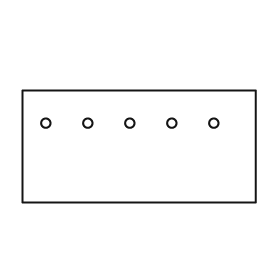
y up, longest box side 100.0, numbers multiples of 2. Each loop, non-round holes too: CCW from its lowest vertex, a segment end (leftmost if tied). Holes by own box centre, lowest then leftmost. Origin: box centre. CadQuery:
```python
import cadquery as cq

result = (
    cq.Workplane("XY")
    .moveTo(-50.0, -24.0)
    .lineTo(50.0, -24.0)
    .lineTo(50.0, 24.0)
    .lineTo(-50.0, 24.0)
    .close()
    .moveTo(-40.0, 10.0)
    .circle(2.0)
    .moveTo(-22.0, 10.0)
    .circle(2.0)
    .moveTo(-4.0, 10.0)
    .circle(2.0)
    .moveTo(14.0, 10.0)
    .circle(2.0)
    .moveTo(32.0, 10.0)
    .circle(2.0)
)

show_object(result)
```